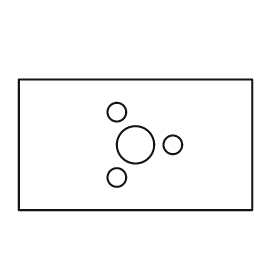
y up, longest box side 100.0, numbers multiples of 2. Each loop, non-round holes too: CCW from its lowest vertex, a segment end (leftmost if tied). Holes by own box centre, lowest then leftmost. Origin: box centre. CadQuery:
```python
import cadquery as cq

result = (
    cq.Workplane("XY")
    .moveTo(-50.0, -28.0)
    .lineTo(50.0, -28.0)
    .lineTo(50.0, 28.0)
    .lineTo(-50.0, 28.0)
    .close()
    .moveTo(-8.0, -14.0)
    .circle(4.0)
    .moveTo(0.0, 0.0)
    .circle(8.0)
    .moveTo(16.0, 0.0)
    .circle(4.0)
    .moveTo(-8.0, 14.0)
    .circle(4.0)
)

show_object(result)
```